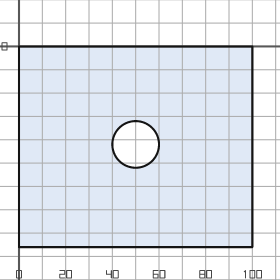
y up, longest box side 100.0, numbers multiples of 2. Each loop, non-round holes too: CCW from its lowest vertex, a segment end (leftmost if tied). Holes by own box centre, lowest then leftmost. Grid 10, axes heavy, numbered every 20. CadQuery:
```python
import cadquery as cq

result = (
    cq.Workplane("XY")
    .moveTo(0.0, -86.0)
    .lineTo(100.0, -86.0)
    .lineTo(100.0, 0.0)
    .lineTo(0.0, 0.0)
    .close()
    .moveTo(50.0, -42.0)
    .circle(10.0)
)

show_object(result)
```